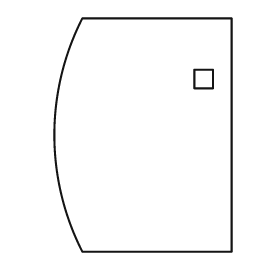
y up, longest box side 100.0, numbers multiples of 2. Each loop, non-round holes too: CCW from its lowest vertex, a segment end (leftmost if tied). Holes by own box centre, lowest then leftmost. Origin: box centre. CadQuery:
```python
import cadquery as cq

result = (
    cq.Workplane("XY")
    .moveTo(-26.0, -50.0)
    .lineTo(38.0, -50.0)
    .lineTo(38.0, 50.0)
    .lineTo(-26.0, 50.0)
    .threePointArc((-38.0, 0.0), (-26.0, -50.0))
    .close()
    .moveTo(22.0, 20.0)
    .lineTo(30.0, 20.0)
    .lineTo(30.0, 28.0)
    .lineTo(22.0, 28.0)
    .close()
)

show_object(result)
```